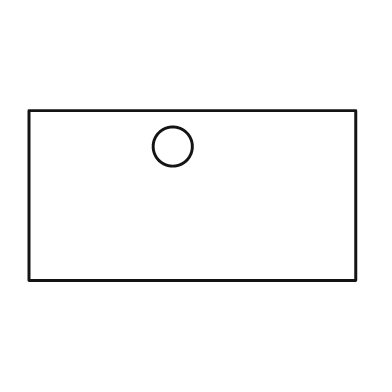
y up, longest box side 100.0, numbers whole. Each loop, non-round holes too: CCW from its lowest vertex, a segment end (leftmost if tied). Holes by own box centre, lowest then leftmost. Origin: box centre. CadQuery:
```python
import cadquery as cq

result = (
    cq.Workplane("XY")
    .moveTo(-50.0, -26.0)
    .lineTo(50.0, -26.0)
    .lineTo(50.0, 26.0)
    .lineTo(-50.0, 26.0)
    .close()
    .moveTo(-6.0, 15.0)
    .circle(6.0)
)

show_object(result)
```